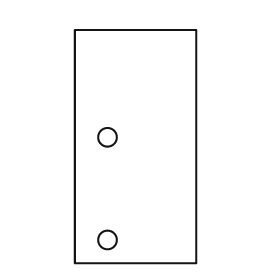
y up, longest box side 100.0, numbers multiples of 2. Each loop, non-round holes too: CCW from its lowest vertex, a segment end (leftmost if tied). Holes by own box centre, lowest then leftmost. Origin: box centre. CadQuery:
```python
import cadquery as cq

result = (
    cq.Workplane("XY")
    .moveTo(-26.0, -50.0)
    .lineTo(26.0, -50.0)
    .lineTo(26.0, 50.0)
    .lineTo(-26.0, 50.0)
    .close()
    .moveTo(-12.0, -40.0)
    .circle(4.0)
    .moveTo(-12.0, 4.0)
    .circle(4.0)
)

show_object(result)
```